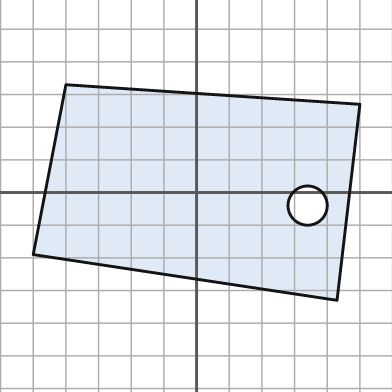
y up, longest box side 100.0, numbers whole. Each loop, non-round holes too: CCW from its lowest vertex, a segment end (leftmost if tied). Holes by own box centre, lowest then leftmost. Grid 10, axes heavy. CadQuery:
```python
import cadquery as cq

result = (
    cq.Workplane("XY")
    .moveTo(43.0, -33.0)
    .lineTo(50.0, 27.0)
    .lineTo(-40.0, 33.0)
    .lineTo(-50.0, -19.0)
    .close()
    .moveTo(34.0, -4.0)
    .circle(6.0)
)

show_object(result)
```